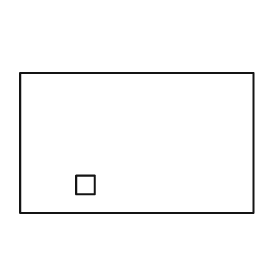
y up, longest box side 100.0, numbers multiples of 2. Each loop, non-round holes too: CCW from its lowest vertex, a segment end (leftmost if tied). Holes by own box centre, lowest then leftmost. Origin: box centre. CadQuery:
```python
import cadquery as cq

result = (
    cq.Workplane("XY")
    .moveTo(-50.0, -30.0)
    .lineTo(50.0, -30.0)
    .lineTo(50.0, 30.0)
    .lineTo(-50.0, 30.0)
    .close()
    .moveTo(-26.0, -22.0)
    .lineTo(-18.0, -22.0)
    .lineTo(-18.0, -14.0)
    .lineTo(-26.0, -14.0)
    .close()
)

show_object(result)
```